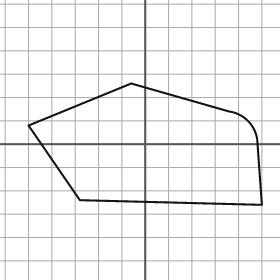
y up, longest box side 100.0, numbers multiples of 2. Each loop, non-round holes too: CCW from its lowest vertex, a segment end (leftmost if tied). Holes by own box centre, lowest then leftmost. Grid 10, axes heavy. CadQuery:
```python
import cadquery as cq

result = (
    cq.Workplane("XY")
    .moveTo(50.0, -26.0)
    .lineTo(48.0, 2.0)
    .threePointArc((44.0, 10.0), (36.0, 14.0))
    .lineTo(-6.0, 26.0)
    .lineTo(-50.0, 8.0)
    .lineTo(-28.0, -24.0)
    .close()
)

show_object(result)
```